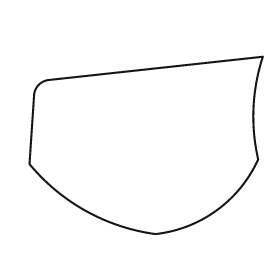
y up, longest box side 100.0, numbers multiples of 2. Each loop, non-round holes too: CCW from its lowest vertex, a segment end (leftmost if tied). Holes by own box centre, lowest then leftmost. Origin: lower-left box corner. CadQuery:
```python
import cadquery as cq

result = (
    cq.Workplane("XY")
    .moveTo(54.0, 0.0)
    .threePointArc((80.0, 10.0), (98.0, 32.0))
    .threePointArc((96.0, 54.0), (100.0, 76.0))
    .lineTo(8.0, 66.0)
    .threePointArc((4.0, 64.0), (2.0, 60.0))
    .lineTo(0.0, 30.0)
    .threePointArc((24.0, 10.0), (54.0, 0.0))
    .close()
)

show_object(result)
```